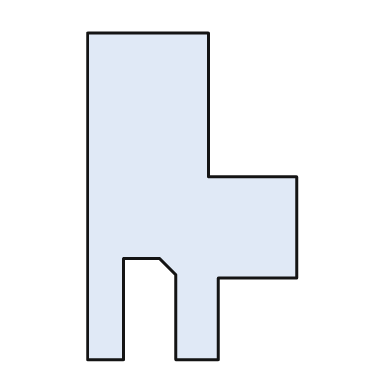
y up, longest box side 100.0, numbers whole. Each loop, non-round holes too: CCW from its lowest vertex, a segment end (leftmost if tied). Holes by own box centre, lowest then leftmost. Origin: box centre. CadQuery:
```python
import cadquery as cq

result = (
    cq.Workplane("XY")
    .moveTo(-32.0, -50.0)
    .lineTo(-21.0, -50.0)
    .lineTo(-21.0, -19.0)
    .lineTo(-10.0, -19.0)
    .lineTo(-5.0, -24.0)
    .lineTo(-5.0, -50.0)
    .lineTo(8.0, -50.0)
    .lineTo(8.0, -25.0)
    .lineTo(32.0, -25.0)
    .lineTo(32.0, 6.0)
    .lineTo(5.0, 6.0)
    .lineTo(5.0, 50.0)
    .lineTo(-32.0, 50.0)
    .close()
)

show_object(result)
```